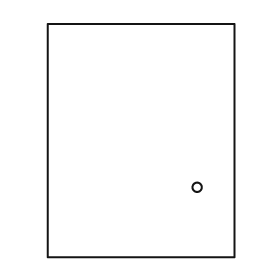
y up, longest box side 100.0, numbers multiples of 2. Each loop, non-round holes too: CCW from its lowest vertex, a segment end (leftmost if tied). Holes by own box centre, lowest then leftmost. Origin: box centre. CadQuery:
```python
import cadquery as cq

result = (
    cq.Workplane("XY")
    .moveTo(-40.0, -50.0)
    .lineTo(40.0, -50.0)
    .lineTo(40.0, 50.0)
    .lineTo(-40.0, 50.0)
    .close()
    .moveTo(24.0, -20.0)
    .circle(2.0)
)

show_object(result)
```